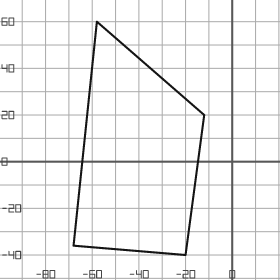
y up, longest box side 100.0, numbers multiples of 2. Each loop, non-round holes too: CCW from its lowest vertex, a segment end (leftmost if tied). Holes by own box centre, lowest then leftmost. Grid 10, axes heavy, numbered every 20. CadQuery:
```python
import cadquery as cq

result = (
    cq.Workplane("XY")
    .moveTo(-20.0, -40.0)
    .lineTo(-12.0, 20.0)
    .lineTo(-58.0, 60.0)
    .lineTo(-68.0, -36.0)
    .close()
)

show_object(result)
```